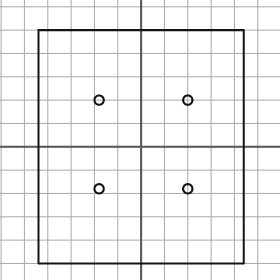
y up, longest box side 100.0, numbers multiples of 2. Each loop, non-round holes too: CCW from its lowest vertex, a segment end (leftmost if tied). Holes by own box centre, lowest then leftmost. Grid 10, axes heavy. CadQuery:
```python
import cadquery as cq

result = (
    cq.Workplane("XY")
    .moveTo(-44.0, -50.0)
    .lineTo(44.0, -50.0)
    .lineTo(44.0, 50.0)
    .lineTo(-44.0, 50.0)
    .close()
    .moveTo(-18.0, -18.0)
    .circle(2.0)
    .moveTo(20.0, -18.0)
    .circle(2.0)
    .moveTo(-18.0, 20.0)
    .circle(2.0)
    .moveTo(20.0, 20.0)
    .circle(2.0)
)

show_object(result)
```